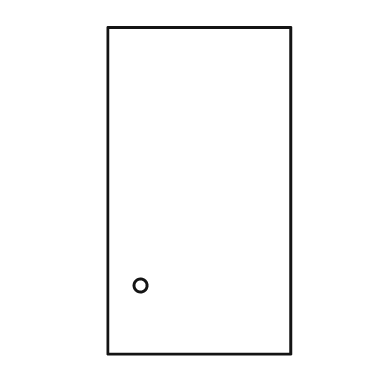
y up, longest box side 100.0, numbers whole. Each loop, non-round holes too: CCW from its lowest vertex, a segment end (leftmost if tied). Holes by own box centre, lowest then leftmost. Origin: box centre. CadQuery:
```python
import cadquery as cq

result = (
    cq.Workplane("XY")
    .moveTo(-28.0, -50.0)
    .lineTo(28.0, -50.0)
    .lineTo(28.0, 50.0)
    .lineTo(-28.0, 50.0)
    .close()
    .moveTo(-18.0, -29.0)
    .circle(2.0)
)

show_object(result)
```